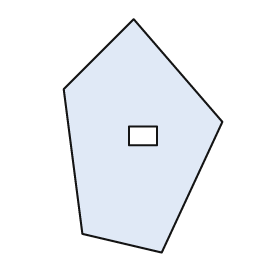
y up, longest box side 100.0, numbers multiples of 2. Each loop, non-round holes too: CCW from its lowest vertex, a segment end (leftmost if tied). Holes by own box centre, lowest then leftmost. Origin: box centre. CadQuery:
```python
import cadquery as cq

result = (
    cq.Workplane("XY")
    .moveTo(8.0, -50.0)
    .lineTo(34.0, 6.0)
    .lineTo(-4.0, 50.0)
    .lineTo(-34.0, 20.0)
    .lineTo(-26.0, -42.0)
    .close()
    .moveTo(-6.0, -4.0)
    .lineTo(6.0, -4.0)
    .lineTo(6.0, 4.0)
    .lineTo(-6.0, 4.0)
    .close()
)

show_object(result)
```